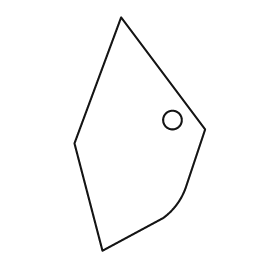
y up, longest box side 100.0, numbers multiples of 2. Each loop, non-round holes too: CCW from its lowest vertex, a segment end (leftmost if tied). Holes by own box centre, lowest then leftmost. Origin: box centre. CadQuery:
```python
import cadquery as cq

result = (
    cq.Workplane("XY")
    .moveTo(-16.0, -50.0)
    .lineTo(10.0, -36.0)
    .threePointArc((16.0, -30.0), (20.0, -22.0))
    .lineTo(28.0, 2.0)
    .lineTo(-8.0, 50.0)
    .lineTo(-28.0, -4.0)
    .close()
    .moveTo(14.0, 6.0)
    .circle(4.0)
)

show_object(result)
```